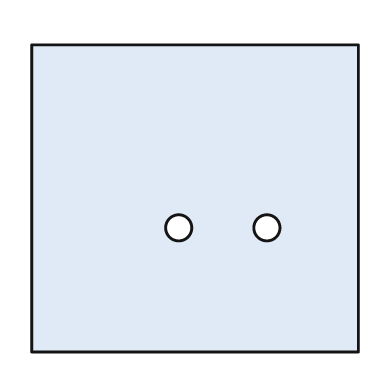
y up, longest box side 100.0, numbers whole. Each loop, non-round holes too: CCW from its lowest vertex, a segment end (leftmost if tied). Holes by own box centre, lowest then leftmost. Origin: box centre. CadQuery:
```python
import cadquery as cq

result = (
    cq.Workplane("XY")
    .moveTo(-50.0, -47.0)
    .lineTo(50.0, -47.0)
    .lineTo(50.0, 47.0)
    .lineTo(-50.0, 47.0)
    .close()
    .moveTo(-5.0, -9.0)
    .circle(4.0)
    .moveTo(22.0, -9.0)
    .circle(4.0)
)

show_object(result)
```